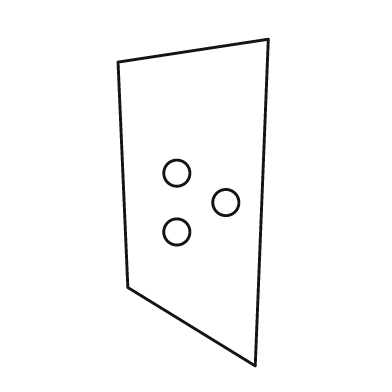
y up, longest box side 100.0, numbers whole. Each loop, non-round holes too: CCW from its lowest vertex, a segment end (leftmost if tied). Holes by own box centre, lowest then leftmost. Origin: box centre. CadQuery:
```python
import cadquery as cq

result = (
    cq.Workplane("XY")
    .moveTo(19.0, -50.0)
    .lineTo(23.0, 50.0)
    .lineTo(-23.0, 43.0)
    .lineTo(-20.0, -26.0)
    .close()
    .moveTo(-5.0, -9.0)
    .circle(4.0)
    .moveTo(10.0, 0.0)
    .circle(4.0)
    .moveTo(-5.0, 9.0)
    .circle(4.0)
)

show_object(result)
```